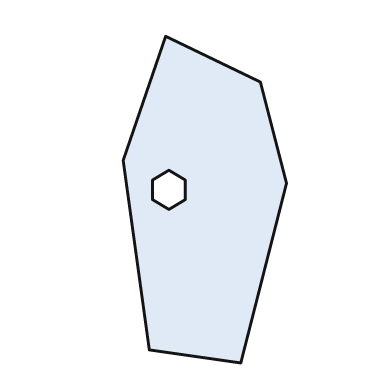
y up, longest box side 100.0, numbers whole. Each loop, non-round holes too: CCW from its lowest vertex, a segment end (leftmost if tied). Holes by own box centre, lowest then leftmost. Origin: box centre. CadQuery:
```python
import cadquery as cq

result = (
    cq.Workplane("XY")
    .moveTo(11.0, -50.0)
    .lineTo(25.0, 5.0)
    .lineTo(17.0, 36.0)
    .lineTo(-12.0, 50.0)
    .lineTo(-25.0, 12.0)
    .lineTo(-17.0, -46.0)
    .close()
    .moveTo(-11.0, -3.0)
    .lineTo(-6.0, 0.0)
    .lineTo(-6.0, 6.0)
    .lineTo(-11.0, 9.0)
    .lineTo(-16.0, 6.0)
    .lineTo(-16.0, 0.0)
    .close()
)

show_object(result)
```